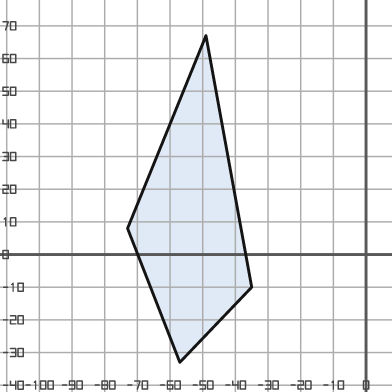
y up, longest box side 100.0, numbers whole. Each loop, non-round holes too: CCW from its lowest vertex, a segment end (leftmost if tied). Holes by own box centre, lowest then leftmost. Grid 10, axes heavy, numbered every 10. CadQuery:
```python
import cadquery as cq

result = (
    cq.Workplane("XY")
    .moveTo(-57.0, -33.0)
    .lineTo(-35.0, -10.0)
    .lineTo(-49.0, 67.0)
    .lineTo(-73.0, 8.0)
    .close()
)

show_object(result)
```